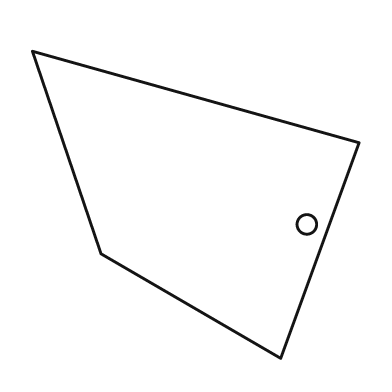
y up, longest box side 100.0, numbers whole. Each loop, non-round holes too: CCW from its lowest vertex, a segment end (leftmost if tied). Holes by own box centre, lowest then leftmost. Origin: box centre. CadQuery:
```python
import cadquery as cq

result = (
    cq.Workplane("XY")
    .moveTo(26.0, -47.0)
    .lineTo(50.0, 19.0)
    .lineTo(-50.0, 47.0)
    .lineTo(-29.0, -15.0)
    .close()
    .moveTo(34.0, -6.0)
    .circle(3.0)
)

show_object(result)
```